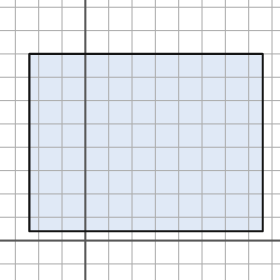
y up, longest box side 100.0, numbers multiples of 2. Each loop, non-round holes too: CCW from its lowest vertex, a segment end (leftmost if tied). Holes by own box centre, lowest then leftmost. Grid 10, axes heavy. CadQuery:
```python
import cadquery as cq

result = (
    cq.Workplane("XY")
    .moveTo(-24.0, 4.0)
    .lineTo(76.0, 4.0)
    .lineTo(76.0, 80.0)
    .lineTo(-24.0, 80.0)
    .close()
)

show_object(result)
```